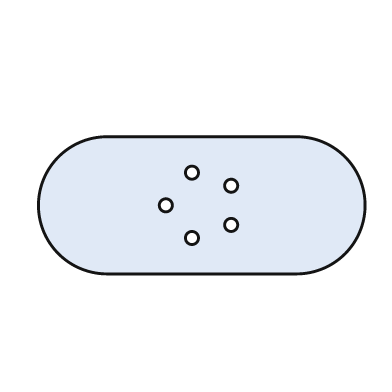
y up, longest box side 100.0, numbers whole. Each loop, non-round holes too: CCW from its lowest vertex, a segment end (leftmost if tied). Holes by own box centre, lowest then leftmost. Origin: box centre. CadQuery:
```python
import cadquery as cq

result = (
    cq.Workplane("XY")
    .moveTo(-29.0, -21.0)
    .lineTo(29.0, -21.0)
    .threePointArc((50.0, 0.0), (29.0, 21.0))
    .lineTo(-29.0, 21.0)
    .threePointArc((-50.0, 0.0), (-29.0, -21.0))
    .close()
    .moveTo(-3.0, -10.0)
    .circle(2.0)
    .moveTo(9.0, -6.0)
    .circle(2.0)
    .moveTo(-11.0, 0.0)
    .circle(2.0)
    .moveTo(9.0, 6.0)
    .circle(2.0)
    .moveTo(-3.0, 10.0)
    .circle(2.0)
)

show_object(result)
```